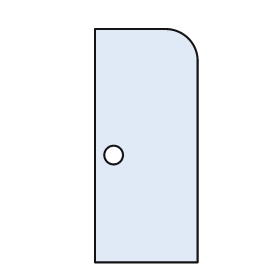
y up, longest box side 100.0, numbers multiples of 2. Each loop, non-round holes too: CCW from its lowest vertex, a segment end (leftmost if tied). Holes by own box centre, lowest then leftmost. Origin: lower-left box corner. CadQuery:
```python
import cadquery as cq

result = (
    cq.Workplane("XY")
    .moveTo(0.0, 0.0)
    .lineTo(44.0, 0.0)
    .lineTo(44.0, 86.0)
    .threePointArc((40.0, 96.0), (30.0, 100.0))
    .lineTo(0.0, 100.0)
    .close()
    .moveTo(8.0, 46.0)
    .circle(4.0)
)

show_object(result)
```